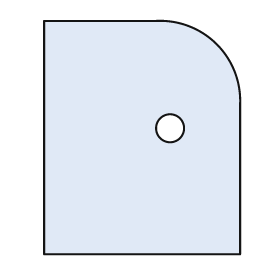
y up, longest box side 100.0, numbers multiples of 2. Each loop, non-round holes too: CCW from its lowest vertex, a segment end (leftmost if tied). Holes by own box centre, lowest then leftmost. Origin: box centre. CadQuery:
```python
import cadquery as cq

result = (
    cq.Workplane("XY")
    .moveTo(-42.0, -50.0)
    .lineTo(42.0, -50.0)
    .lineTo(42.0, 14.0)
    .threePointArc((32.0, 40.0), (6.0, 50.0))
    .lineTo(-42.0, 50.0)
    .close()
    .moveTo(12.0, 4.0)
    .circle(6.0)
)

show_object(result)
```